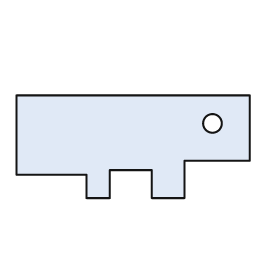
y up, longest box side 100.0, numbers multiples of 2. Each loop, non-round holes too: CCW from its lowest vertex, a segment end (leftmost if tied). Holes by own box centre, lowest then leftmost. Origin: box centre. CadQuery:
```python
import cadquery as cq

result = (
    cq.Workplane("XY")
    .moveTo(-20.0, -22.0)
    .lineTo(-10.0, -22.0)
    .lineTo(-10.0, -10.0)
    .lineTo(8.0, -10.0)
    .lineTo(8.0, -22.0)
    .lineTo(22.0, -22.0)
    .lineTo(22.0, -6.0)
    .lineTo(50.0, -6.0)
    .lineTo(50.0, 22.0)
    .lineTo(-50.0, 22.0)
    .lineTo(-50.0, -12.0)
    .lineTo(-20.0, -12.0)
    .close()
    .moveTo(34.0, 10.0)
    .circle(4.0)
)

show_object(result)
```